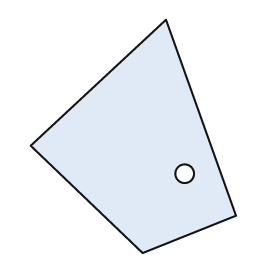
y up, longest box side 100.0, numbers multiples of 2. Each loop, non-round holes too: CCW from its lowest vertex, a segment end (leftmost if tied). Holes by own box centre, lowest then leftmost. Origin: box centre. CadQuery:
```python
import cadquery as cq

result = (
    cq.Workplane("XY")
    .moveTo(4.0, -50.0)
    .lineTo(44.0, -34.0)
    .lineTo(14.0, 50.0)
    .lineTo(-44.0, -4.0)
    .close()
    .moveTo(22.0, -16.0)
    .circle(4.0)
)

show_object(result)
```